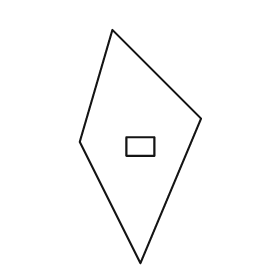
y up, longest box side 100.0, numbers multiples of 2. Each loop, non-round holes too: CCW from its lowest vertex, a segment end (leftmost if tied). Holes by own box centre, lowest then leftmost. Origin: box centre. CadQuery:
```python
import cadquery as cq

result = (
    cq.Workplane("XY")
    .moveTo(0.0, -50.0)
    .lineTo(26.0, 12.0)
    .lineTo(-12.0, 50.0)
    .lineTo(-26.0, 2.0)
    .close()
    .moveTo(-6.0, -4.0)
    .lineTo(6.0, -4.0)
    .lineTo(6.0, 4.0)
    .lineTo(-6.0, 4.0)
    .close()
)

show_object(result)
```